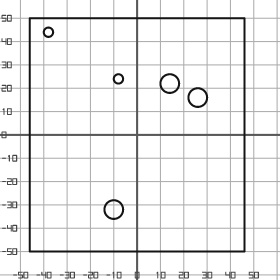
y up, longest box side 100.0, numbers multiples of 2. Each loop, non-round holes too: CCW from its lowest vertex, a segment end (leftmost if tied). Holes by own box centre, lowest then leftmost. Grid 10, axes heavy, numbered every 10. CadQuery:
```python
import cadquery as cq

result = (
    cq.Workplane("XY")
    .moveTo(-46.0, -50.0)
    .lineTo(46.0, -50.0)
    .lineTo(46.0, 50.0)
    .lineTo(-46.0, 50.0)
    .close()
    .moveTo(-10.0, -32.0)
    .circle(4.0)
    .moveTo(26.0, 16.0)
    .circle(4.0)
    .moveTo(14.0, 22.0)
    .circle(4.0)
    .moveTo(-8.0, 24.0)
    .circle(2.0)
    .moveTo(-38.0, 44.0)
    .circle(2.0)
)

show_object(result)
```